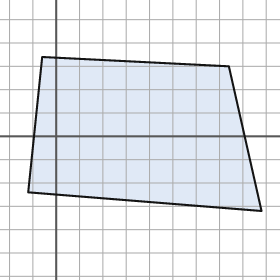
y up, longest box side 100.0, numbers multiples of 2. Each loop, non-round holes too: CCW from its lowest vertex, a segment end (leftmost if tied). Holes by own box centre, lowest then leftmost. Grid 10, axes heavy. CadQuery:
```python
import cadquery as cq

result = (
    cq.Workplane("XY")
    .moveTo(88.0, -32.0)
    .lineTo(74.0, 30.0)
    .lineTo(-6.0, 34.0)
    .lineTo(-12.0, -24.0)
    .close()
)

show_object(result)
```